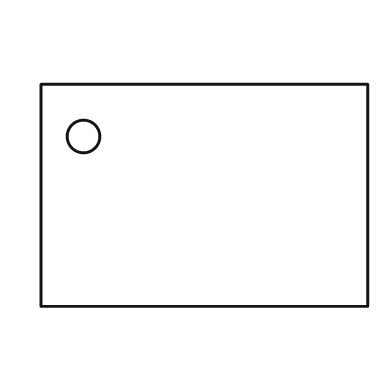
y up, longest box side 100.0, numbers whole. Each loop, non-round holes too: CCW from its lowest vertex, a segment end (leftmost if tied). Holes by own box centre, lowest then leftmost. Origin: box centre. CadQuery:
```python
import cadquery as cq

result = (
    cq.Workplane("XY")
    .moveTo(-50.0, -34.0)
    .lineTo(50.0, -34.0)
    .lineTo(50.0, 34.0)
    .lineTo(-50.0, 34.0)
    .close()
    .moveTo(-37.0, 18.0)
    .circle(5.0)
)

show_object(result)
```